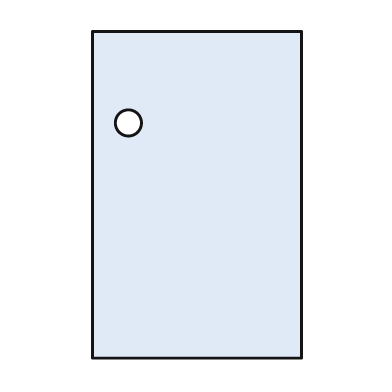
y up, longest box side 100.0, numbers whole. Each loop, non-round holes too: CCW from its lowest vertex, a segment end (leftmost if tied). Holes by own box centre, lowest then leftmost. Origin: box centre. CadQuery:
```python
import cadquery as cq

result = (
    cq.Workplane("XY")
    .moveTo(-32.0, -50.0)
    .lineTo(32.0, -50.0)
    .lineTo(32.0, 50.0)
    .lineTo(-32.0, 50.0)
    .close()
    .moveTo(-21.0, 22.0)
    .circle(4.0)
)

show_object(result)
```